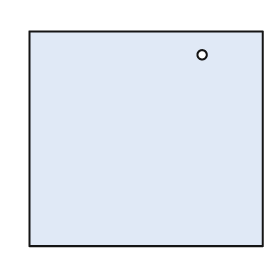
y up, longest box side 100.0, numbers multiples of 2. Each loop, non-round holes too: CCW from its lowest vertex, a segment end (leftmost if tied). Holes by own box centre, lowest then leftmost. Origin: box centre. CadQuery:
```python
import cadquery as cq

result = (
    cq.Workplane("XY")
    .moveTo(-50.0, -46.0)
    .lineTo(50.0, -46.0)
    .lineTo(50.0, 46.0)
    .lineTo(-50.0, 46.0)
    .close()
    .moveTo(24.0, 36.0)
    .circle(2.0)
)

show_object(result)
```